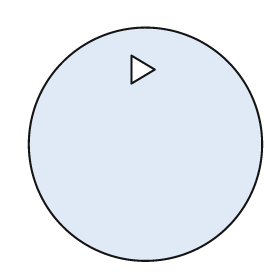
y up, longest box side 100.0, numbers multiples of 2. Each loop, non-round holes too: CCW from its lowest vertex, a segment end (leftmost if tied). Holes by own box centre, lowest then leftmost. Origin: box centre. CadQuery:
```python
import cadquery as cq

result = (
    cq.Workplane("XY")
    .moveTo(0.0, 0.0)
    .circle(50.0)
    .moveTo(-6.0, 26.0)
    .lineTo(4.0, 32.0)
    .lineTo(-6.0, 38.0)
    .close()
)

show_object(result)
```